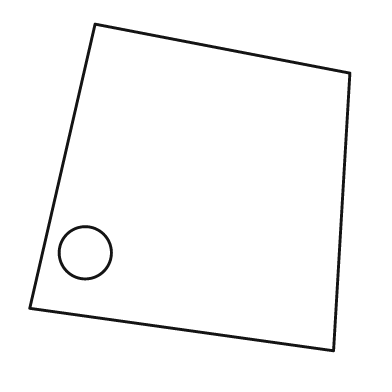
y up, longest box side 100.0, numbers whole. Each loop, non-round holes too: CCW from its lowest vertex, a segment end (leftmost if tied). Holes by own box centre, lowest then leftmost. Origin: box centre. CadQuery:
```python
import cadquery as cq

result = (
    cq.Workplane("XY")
    .moveTo(44.0, -50.0)
    .lineTo(49.0, 35.0)
    .lineTo(-29.0, 50.0)
    .lineTo(-49.0, -37.0)
    .close()
    .moveTo(-32.0, -20.0)
    .circle(8.0)
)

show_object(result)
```